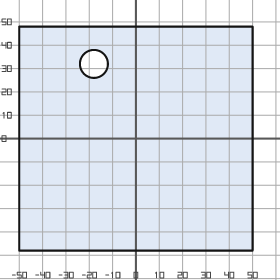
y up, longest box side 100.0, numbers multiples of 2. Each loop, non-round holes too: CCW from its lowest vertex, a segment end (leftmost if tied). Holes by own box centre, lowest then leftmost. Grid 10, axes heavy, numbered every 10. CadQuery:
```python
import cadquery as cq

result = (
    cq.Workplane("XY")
    .moveTo(-50.0, -48.0)
    .lineTo(50.0, -48.0)
    .lineTo(50.0, 48.0)
    .lineTo(-50.0, 48.0)
    .close()
    .moveTo(-18.0, 32.0)
    .circle(6.0)
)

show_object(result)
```